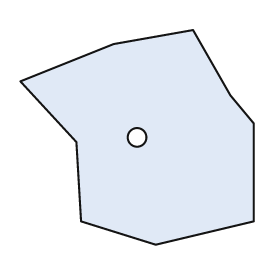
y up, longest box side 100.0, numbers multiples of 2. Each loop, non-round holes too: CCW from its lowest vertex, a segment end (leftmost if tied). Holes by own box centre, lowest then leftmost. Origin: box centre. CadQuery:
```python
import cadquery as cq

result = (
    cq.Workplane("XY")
    .moveTo(8.0, -46.0)
    .lineTo(50.0, -36.0)
    .lineTo(50.0, 6.0)
    .lineTo(40.0, 18.0)
    .lineTo(24.0, 46.0)
    .lineTo(-10.0, 40.0)
    .lineTo(-50.0, 24.0)
    .lineTo(-26.0, -2.0)
    .lineTo(-24.0, -36.0)
    .close()
    .moveTo(0.0, 0.0)
    .circle(4.0)
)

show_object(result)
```